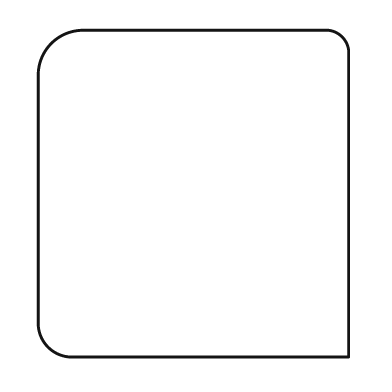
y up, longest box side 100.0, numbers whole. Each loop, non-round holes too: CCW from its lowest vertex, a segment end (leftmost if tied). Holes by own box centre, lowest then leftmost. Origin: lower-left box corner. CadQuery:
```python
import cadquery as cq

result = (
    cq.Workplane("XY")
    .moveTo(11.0, 0.0)
    .lineTo(95.0, 0.0)
    .lineTo(95.0, 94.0)
    .threePointArc((93.0, 98.0), (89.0, 100.0))
    .lineTo(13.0, 100.0)
    .threePointArc((4.0, 96.0), (0.0, 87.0))
    .lineTo(0.0, 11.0)
    .threePointArc((3.0, 3.0), (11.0, 0.0))
    .close()
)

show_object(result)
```